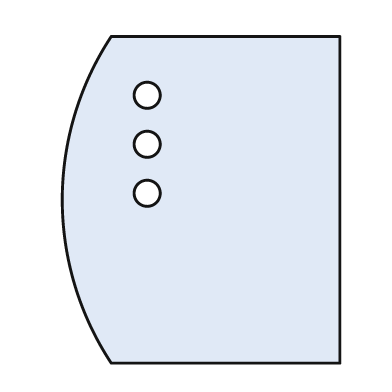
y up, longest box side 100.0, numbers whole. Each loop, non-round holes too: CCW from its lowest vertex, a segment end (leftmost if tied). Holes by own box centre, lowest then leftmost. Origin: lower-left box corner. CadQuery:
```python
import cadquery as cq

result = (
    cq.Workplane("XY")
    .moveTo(15.0, 0.0)
    .lineTo(85.0, 0.0)
    .lineTo(85.0, 100.0)
    .lineTo(15.0, 100.0)
    .threePointArc((0.0, 50.0), (15.0, 0.0))
    .close()
    .moveTo(26.0, 52.0)
    .circle(4.0)
    .moveTo(26.0, 67.0)
    .circle(4.0)
    .moveTo(26.0, 82.0)
    .circle(4.0)
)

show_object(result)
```